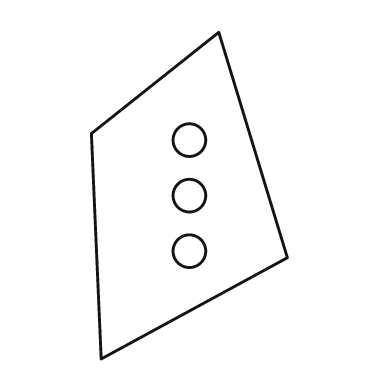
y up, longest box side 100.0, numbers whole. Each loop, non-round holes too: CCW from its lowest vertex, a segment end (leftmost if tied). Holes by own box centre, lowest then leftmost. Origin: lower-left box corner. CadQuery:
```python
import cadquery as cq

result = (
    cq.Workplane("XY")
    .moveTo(3.0, 0.0)
    .lineTo(60.0, 31.0)
    .lineTo(39.0, 100.0)
    .lineTo(0.0, 69.0)
    .close()
    .moveTo(30.0, 33.0)
    .circle(5.0)
    .moveTo(30.0, 50.0)
    .circle(5.0)
    .moveTo(30.0, 67.0)
    .circle(5.0)
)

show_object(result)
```